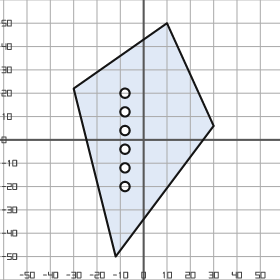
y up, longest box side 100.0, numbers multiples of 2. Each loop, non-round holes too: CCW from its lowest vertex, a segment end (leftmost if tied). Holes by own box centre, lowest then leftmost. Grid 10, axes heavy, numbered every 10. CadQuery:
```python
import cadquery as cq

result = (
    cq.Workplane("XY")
    .moveTo(-12.0, -50.0)
    .lineTo(30.0, 6.0)
    .lineTo(10.0, 50.0)
    .lineTo(-30.0, 22.0)
    .close()
    .moveTo(-8.0, -20.0)
    .circle(2.0)
    .moveTo(-8.0, -12.0)
    .circle(2.0)
    .moveTo(-8.0, -4.0)
    .circle(2.0)
    .moveTo(-8.0, 4.0)
    .circle(2.0)
    .moveTo(-8.0, 12.0)
    .circle(2.0)
    .moveTo(-8.0, 20.0)
    .circle(2.0)
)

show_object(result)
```